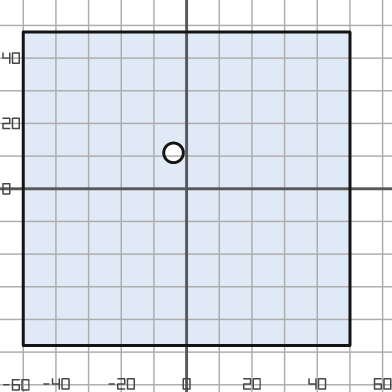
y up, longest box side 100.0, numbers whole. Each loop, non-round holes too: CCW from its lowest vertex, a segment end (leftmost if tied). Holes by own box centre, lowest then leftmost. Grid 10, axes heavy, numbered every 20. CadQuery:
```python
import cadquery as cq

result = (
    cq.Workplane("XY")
    .moveTo(-50.0, -48.0)
    .lineTo(50.0, -48.0)
    .lineTo(50.0, 48.0)
    .lineTo(-50.0, 48.0)
    .close()
    .moveTo(-4.0, 11.0)
    .circle(3.0)
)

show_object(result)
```